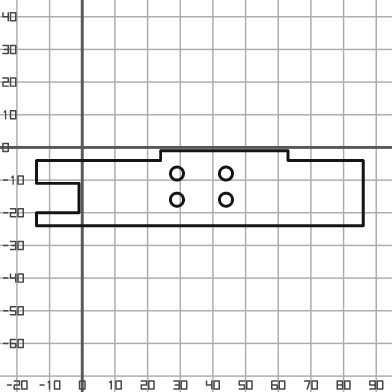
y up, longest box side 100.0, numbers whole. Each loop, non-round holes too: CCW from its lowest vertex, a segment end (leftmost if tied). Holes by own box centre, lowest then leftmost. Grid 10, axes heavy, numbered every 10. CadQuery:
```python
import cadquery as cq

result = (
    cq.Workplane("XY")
    .moveTo(-14.0, -24.0)
    .lineTo(86.0, -24.0)
    .lineTo(86.0, -4.0)
    .lineTo(63.0, -4.0)
    .lineTo(63.0, -1.0)
    .lineTo(24.0, -1.0)
    .lineTo(24.0, -4.0)
    .lineTo(-14.0, -4.0)
    .lineTo(-14.0, -11.0)
    .lineTo(-1.0, -11.0)
    .lineTo(-1.0, -20.0)
    .lineTo(-14.0, -20.0)
    .close()
    .moveTo(29.0, -16.0)
    .circle(2.0)
    .moveTo(44.0, -16.0)
    .circle(2.0)
    .moveTo(29.0, -8.0)
    .circle(2.0)
    .moveTo(44.0, -8.0)
    .circle(2.0)
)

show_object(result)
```